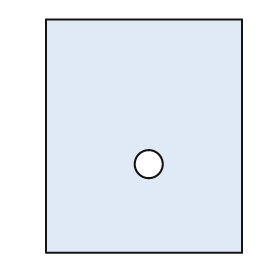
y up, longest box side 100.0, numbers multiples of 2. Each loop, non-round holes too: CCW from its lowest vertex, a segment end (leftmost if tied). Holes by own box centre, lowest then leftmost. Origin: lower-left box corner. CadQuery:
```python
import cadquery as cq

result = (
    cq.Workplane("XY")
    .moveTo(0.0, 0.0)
    .lineTo(84.0, 0.0)
    .lineTo(84.0, 100.0)
    .lineTo(0.0, 100.0)
    .close()
    .moveTo(44.0, 38.0)
    .circle(6.0)
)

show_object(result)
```